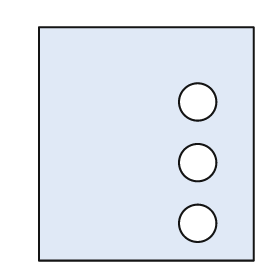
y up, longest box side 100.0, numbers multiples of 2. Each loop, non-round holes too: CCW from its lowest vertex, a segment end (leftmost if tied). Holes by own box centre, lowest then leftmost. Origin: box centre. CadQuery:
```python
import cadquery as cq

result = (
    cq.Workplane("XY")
    .moveTo(-46.0, -50.0)
    .lineTo(46.0, -50.0)
    .lineTo(46.0, 50.0)
    .lineTo(-46.0, 50.0)
    .close()
    .moveTo(22.0, -34.0)
    .circle(8.0)
    .moveTo(22.0, -8.0)
    .circle(8.0)
    .moveTo(22.0, 18.0)
    .circle(8.0)
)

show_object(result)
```